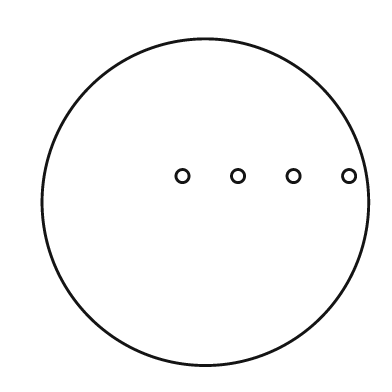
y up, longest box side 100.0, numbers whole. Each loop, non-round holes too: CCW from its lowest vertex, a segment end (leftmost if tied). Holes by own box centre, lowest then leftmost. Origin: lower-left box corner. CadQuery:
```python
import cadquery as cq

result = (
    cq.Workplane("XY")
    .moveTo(50.0, 50.0)
    .circle(50.0)
    .moveTo(43.0, 58.0)
    .circle(2.0)
    .moveTo(60.0, 58.0)
    .circle(2.0)
    .moveTo(77.0, 58.0)
    .circle(2.0)
    .moveTo(94.0, 58.0)
    .circle(2.0)
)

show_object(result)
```